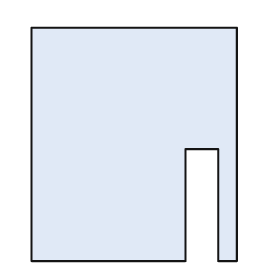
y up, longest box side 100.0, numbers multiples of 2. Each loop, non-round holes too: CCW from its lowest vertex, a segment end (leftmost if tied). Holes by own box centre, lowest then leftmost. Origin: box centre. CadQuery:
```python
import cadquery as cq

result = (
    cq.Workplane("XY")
    .moveTo(-44.0, -50.0)
    .lineTo(22.0, -50.0)
    .lineTo(22.0, -2.0)
    .lineTo(36.0, -2.0)
    .lineTo(36.0, -50.0)
    .lineTo(44.0, -50.0)
    .lineTo(44.0, 50.0)
    .lineTo(-44.0, 50.0)
    .close()
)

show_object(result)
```